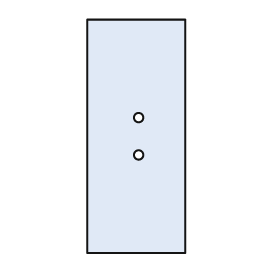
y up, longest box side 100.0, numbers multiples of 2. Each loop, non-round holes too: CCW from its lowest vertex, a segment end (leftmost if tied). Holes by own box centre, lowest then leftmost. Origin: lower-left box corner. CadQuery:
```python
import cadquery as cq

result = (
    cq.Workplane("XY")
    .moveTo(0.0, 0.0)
    .lineTo(42.0, 0.0)
    .lineTo(42.0, 100.0)
    .lineTo(0.0, 100.0)
    .close()
    .moveTo(22.0, 42.0)
    .circle(2.0)
    .moveTo(22.0, 58.0)
    .circle(2.0)
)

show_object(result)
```